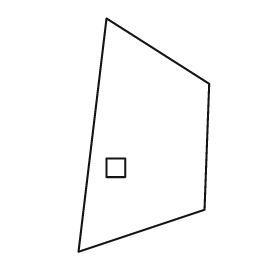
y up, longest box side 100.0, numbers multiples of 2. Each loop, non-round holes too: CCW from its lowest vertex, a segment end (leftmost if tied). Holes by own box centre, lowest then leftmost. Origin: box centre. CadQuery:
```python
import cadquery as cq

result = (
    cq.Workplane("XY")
    .moveTo(-28.0, -50.0)
    .lineTo(26.0, -32.0)
    .lineTo(28.0, 22.0)
    .lineTo(-16.0, 50.0)
    .close()
    .moveTo(-16.0, -18.0)
    .lineTo(-8.0, -18.0)
    .lineTo(-8.0, -10.0)
    .lineTo(-16.0, -10.0)
    .close()
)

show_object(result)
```